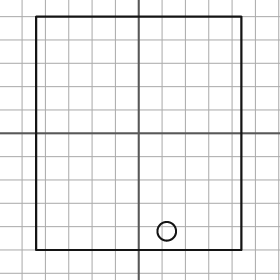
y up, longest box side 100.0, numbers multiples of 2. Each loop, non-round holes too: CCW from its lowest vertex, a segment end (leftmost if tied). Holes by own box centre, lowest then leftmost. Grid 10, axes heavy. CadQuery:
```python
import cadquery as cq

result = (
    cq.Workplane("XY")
    .moveTo(-44.0, -50.0)
    .lineTo(44.0, -50.0)
    .lineTo(44.0, 50.0)
    .lineTo(-44.0, 50.0)
    .close()
    .moveTo(12.0, -42.0)
    .circle(4.0)
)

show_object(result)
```